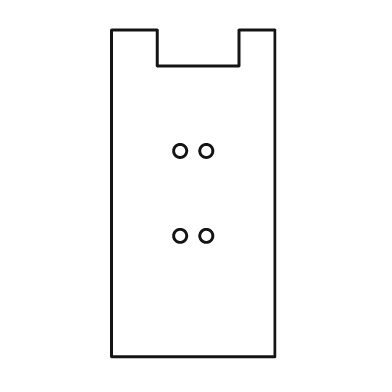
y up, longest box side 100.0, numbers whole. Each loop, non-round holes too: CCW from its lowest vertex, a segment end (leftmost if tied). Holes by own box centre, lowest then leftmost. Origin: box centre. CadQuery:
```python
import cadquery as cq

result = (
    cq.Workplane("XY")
    .moveTo(-25.0, -50.0)
    .lineTo(25.0, -50.0)
    .lineTo(25.0, 50.0)
    .lineTo(14.0, 50.0)
    .lineTo(14.0, 39.0)
    .lineTo(-11.0, 39.0)
    .lineTo(-11.0, 50.0)
    .lineTo(-25.0, 50.0)
    .close()
    .moveTo(-4.0, -13.0)
    .circle(2.0)
    .moveTo(4.0, -13.0)
    .circle(2.0)
    .moveTo(-4.0, 13.0)
    .circle(2.0)
    .moveTo(4.0, 13.0)
    .circle(2.0)
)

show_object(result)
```